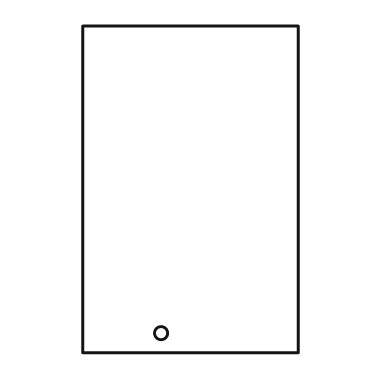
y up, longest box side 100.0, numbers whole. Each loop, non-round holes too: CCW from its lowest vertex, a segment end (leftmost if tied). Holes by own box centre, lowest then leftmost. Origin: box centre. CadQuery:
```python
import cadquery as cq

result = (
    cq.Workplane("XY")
    .moveTo(-33.0, -50.0)
    .lineTo(33.0, -50.0)
    .lineTo(33.0, 50.0)
    .lineTo(-33.0, 50.0)
    .close()
    .moveTo(-9.0, -44.0)
    .circle(2.0)
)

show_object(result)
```